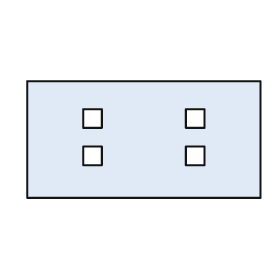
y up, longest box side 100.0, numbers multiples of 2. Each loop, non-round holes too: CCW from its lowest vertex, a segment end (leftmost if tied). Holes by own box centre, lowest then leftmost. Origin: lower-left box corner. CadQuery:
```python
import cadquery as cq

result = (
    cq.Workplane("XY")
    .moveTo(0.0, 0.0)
    .lineTo(100.0, 0.0)
    .lineTo(100.0, 50.0)
    .lineTo(0.0, 50.0)
    .close()
    .moveTo(24.0, 14.0)
    .lineTo(32.0, 14.0)
    .lineTo(32.0, 22.0)
    .lineTo(24.0, 22.0)
    .close()
    .moveTo(68.0, 14.0)
    .lineTo(76.0, 14.0)
    .lineTo(76.0, 22.0)
    .lineTo(68.0, 22.0)
    .close()
    .moveTo(24.0, 30.0)
    .lineTo(32.0, 30.0)
    .lineTo(32.0, 38.0)
    .lineTo(24.0, 38.0)
    .close()
    .moveTo(68.0, 30.0)
    .lineTo(76.0, 30.0)
    .lineTo(76.0, 38.0)
    .lineTo(68.0, 38.0)
    .close()
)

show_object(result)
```